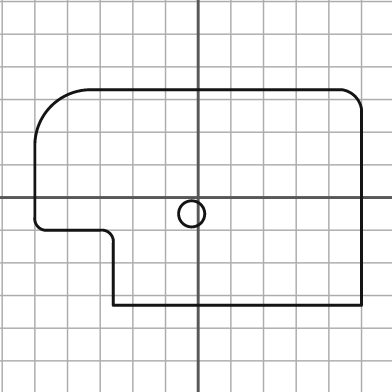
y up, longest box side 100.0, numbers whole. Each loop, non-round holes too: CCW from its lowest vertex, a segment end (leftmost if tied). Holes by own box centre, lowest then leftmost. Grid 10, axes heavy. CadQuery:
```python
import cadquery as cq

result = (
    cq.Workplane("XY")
    .moveTo(-26.0, -33.0)
    .lineTo(50.0, -33.0)
    .lineTo(50.0, 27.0)
    .threePointArc((48.0, 31.0), (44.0, 33.0))
    .lineTo(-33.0, 33.0)
    .threePointArc((-45.0, 28.0), (-50.0, 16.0))
    .lineTo(-50.0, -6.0)
    .threePointArc((-49.0, -9.0), (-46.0, -10.0))
    .lineTo(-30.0, -10.0)
    .threePointArc((-27.0, -11.0), (-26.0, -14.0))
    .close()
    .moveTo(-2.0, -5.0)
    .circle(4.0)
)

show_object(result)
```